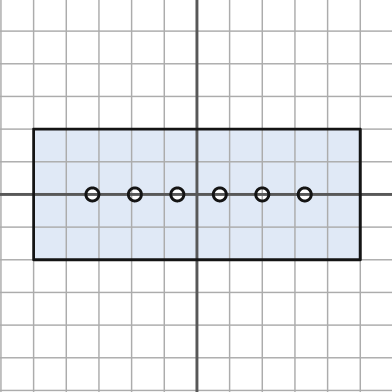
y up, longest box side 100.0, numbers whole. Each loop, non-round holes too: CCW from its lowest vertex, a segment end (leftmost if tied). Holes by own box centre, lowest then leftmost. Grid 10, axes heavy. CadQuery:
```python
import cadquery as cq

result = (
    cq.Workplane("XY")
    .moveTo(-50.0, -20.0)
    .lineTo(50.0, -20.0)
    .lineTo(50.0, 20.0)
    .lineTo(-50.0, 20.0)
    .close()
    .moveTo(-32.0, 0.0)
    .circle(2.0)
    .moveTo(-19.0, 0.0)
    .circle(2.0)
    .moveTo(-6.0, 0.0)
    .circle(2.0)
    .moveTo(7.0, 0.0)
    .circle(2.0)
    .moveTo(20.0, 0.0)
    .circle(2.0)
    .moveTo(33.0, 0.0)
    .circle(2.0)
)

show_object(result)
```